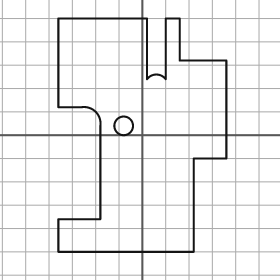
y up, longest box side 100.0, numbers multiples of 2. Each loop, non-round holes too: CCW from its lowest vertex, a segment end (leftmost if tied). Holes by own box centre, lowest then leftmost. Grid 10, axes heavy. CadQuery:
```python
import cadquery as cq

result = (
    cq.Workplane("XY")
    .moveTo(-36.0, -50.0)
    .lineTo(22.0, -50.0)
    .lineTo(22.0, -10.0)
    .lineTo(36.0, -10.0)
    .lineTo(36.0, 32.0)
    .lineTo(16.0, 32.0)
    .lineTo(16.0, 50.0)
    .lineTo(10.0, 50.0)
    .lineTo(10.0, 24.0)
    .threePointArc((6.0, 26.0), (2.0, 24.0))
    .lineTo(2.0, 50.0)
    .lineTo(-36.0, 50.0)
    .lineTo(-36.0, 12.0)
    .lineTo(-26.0, 12.0)
    .threePointArc((-20.0, 10.0), (-18.0, 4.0))
    .lineTo(-18.0, -36.0)
    .lineTo(-36.0, -36.0)
    .close()
    .moveTo(-8.0, 4.0)
    .circle(4.0)
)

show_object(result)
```